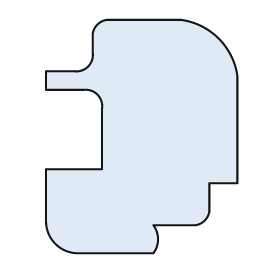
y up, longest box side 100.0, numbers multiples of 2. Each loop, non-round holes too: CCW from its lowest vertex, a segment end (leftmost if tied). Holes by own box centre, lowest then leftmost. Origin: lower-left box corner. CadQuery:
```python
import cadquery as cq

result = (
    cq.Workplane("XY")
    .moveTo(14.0, 0.0)
    .lineTo(46.0, 0.0)
    .threePointArc((48.0, 6.0), (46.0, 12.0))
    .lineTo(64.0, 12.0)
    .threePointArc((68.0, 14.0), (70.0, 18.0))
    .lineTo(70.0, 30.0)
    .lineTo(82.0, 30.0)
    .lineTo(82.0, 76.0)
    .threePointArc((74.0, 92.0), (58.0, 100.0))
    .lineTo(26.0, 100.0)
    .threePointArc((22.0, 98.0), (20.0, 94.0))
    .lineTo(20.0, 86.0)
    .threePointArc((18.0, 80.0), (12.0, 78.0))
    .lineTo(0.0, 78.0)
    .lineTo(0.0, 70.0)
    .lineTo(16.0, 70.0)
    .threePointArc((22.0, 68.0), (24.0, 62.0))
    .lineTo(24.0, 36.0)
    .lineTo(0.0, 36.0)
    .lineTo(0.0, 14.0)
    .threePointArc((4.0, 4.0), (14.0, 0.0))
    .close()
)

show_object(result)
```